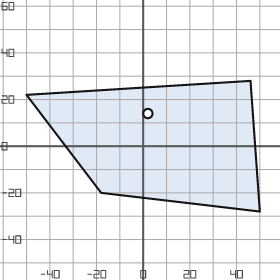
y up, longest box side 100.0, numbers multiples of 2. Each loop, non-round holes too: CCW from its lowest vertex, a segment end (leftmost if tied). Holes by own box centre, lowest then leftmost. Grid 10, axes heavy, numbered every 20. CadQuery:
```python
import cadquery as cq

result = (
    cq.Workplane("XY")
    .moveTo(50.0, -28.0)
    .lineTo(46.0, 28.0)
    .lineTo(-50.0, 22.0)
    .lineTo(-18.0, -20.0)
    .close()
    .moveTo(2.0, 14.0)
    .circle(2.0)
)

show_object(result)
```